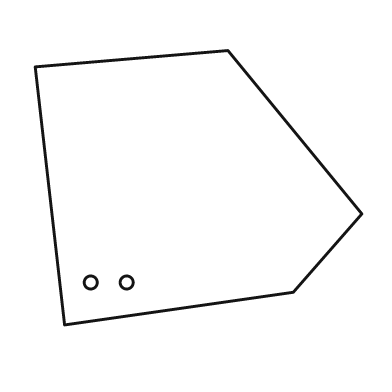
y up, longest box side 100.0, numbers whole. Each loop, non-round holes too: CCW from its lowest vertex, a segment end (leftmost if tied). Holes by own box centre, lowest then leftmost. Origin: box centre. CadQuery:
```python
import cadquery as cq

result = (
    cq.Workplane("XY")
    .moveTo(-41.0, -42.0)
    .lineTo(29.0, -32.0)
    .lineTo(50.0, -8.0)
    .lineTo(9.0, 42.0)
    .lineTo(-50.0, 37.0)
    .close()
    .moveTo(-33.0, -29.0)
    .circle(2.0)
    .moveTo(-22.0, -29.0)
    .circle(2.0)
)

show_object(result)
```